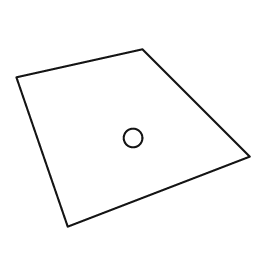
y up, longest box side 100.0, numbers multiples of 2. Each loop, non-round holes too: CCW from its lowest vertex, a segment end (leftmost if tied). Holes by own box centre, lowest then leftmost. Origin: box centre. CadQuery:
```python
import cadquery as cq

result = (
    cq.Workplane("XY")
    .moveTo(-28.0, -38.0)
    .lineTo(50.0, -8.0)
    .lineTo(4.0, 38.0)
    .lineTo(-50.0, 26.0)
    .close()
    .moveTo(0.0, 0.0)
    .circle(4.0)
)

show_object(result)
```